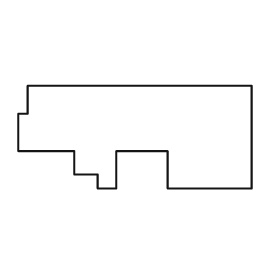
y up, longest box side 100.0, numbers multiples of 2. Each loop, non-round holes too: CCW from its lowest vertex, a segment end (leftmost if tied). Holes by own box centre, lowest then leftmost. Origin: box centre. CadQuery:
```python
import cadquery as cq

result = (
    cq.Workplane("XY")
    .moveTo(-16.0, -22.0)
    .lineTo(-8.0, -22.0)
    .lineTo(-8.0, -6.0)
    .lineTo(14.0, -6.0)
    .lineTo(14.0, -22.0)
    .lineTo(50.0, -22.0)
    .lineTo(50.0, 22.0)
    .lineTo(-46.0, 22.0)
    .lineTo(-46.0, 10.0)
    .lineTo(-50.0, 10.0)
    .lineTo(-50.0, -6.0)
    .lineTo(-26.0, -6.0)
    .lineTo(-26.0, -16.0)
    .lineTo(-16.0, -16.0)
    .close()
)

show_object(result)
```